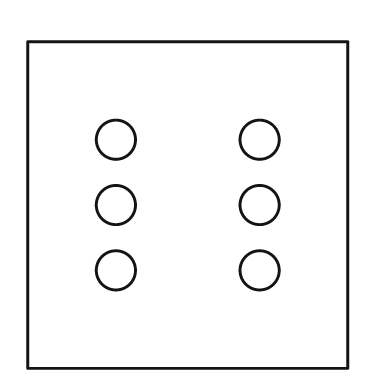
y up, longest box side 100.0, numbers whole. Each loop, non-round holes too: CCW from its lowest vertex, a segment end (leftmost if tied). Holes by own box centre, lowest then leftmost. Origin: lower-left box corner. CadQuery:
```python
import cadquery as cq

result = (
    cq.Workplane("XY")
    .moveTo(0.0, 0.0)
    .lineTo(98.0, 0.0)
    .lineTo(98.0, 100.0)
    .lineTo(0.0, 100.0)
    .close()
    .moveTo(27.0, 30.0)
    .circle(6.0)
    .moveTo(71.0, 30.0)
    .circle(6.0)
    .moveTo(27.0, 50.0)
    .circle(6.0)
    .moveTo(71.0, 50.0)
    .circle(6.0)
    .moveTo(27.0, 70.0)
    .circle(6.0)
    .moveTo(71.0, 70.0)
    .circle(6.0)
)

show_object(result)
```